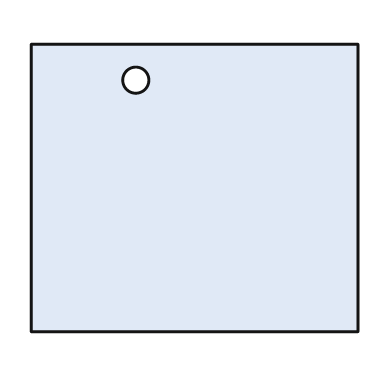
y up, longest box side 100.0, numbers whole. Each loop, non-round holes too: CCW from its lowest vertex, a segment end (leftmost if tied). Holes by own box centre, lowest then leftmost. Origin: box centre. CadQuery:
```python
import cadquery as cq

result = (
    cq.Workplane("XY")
    .moveTo(-50.0, -44.0)
    .lineTo(50.0, -44.0)
    .lineTo(50.0, 44.0)
    .lineTo(-50.0, 44.0)
    .close()
    .moveTo(-18.0, 33.0)
    .circle(4.0)
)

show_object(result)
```